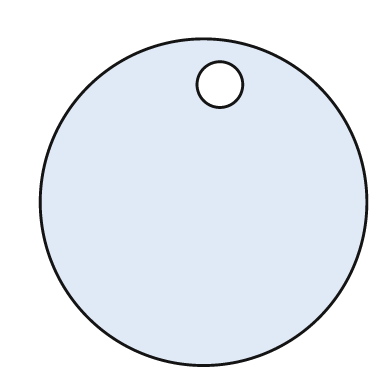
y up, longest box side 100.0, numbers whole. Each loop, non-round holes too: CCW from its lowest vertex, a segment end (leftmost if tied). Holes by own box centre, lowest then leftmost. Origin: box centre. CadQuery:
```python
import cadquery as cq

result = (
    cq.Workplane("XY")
    .moveTo(0.0, 0.0)
    .circle(50.0)
    .moveTo(5.0, 36.0)
    .circle(7.0)
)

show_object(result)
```